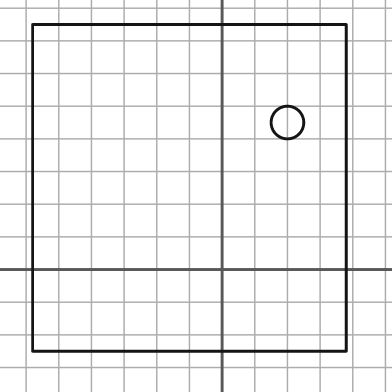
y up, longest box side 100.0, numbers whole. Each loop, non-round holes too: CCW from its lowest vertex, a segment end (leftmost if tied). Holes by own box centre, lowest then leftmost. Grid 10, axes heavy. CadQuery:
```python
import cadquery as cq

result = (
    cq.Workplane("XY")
    .moveTo(-58.0, -25.0)
    .lineTo(38.0, -25.0)
    .lineTo(38.0, 75.0)
    .lineTo(-58.0, 75.0)
    .close()
    .moveTo(20.0, 45.0)
    .circle(5.0)
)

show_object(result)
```